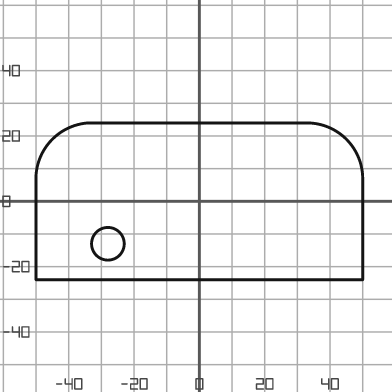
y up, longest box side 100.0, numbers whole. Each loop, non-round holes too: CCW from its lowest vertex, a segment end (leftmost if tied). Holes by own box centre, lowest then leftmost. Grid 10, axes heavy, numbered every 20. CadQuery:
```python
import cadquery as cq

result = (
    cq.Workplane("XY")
    .moveTo(-50.0, -24.0)
    .lineTo(50.0, -24.0)
    .lineTo(50.0, 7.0)
    .threePointArc((45.0, 19.0), (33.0, 24.0))
    .lineTo(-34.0, 24.0)
    .threePointArc((-45.0, 19.0), (-50.0, 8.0))
    .close()
    .moveTo(-28.0, -13.0)
    .circle(5.0)
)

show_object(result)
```